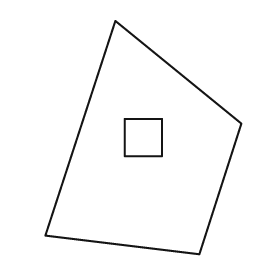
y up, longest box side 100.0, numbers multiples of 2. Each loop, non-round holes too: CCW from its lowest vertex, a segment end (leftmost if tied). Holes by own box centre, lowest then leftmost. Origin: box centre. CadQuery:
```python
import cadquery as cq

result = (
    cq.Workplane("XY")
    .moveTo(24.0, -50.0)
    .lineTo(42.0, 6.0)
    .lineTo(-12.0, 50.0)
    .lineTo(-42.0, -42.0)
    .close()
    .moveTo(-8.0, -8.0)
    .lineTo(8.0, -8.0)
    .lineTo(8.0, 8.0)
    .lineTo(-8.0, 8.0)
    .close()
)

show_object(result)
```